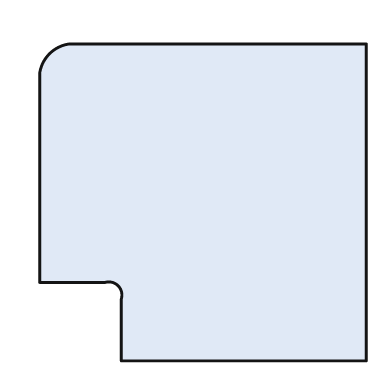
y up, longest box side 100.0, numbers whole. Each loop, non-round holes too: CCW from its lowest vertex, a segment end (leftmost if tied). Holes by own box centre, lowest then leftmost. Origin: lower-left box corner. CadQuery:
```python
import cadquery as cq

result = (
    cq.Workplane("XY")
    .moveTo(25.0, 0.0)
    .lineTo(100.0, 0.0)
    .lineTo(100.0, 97.0)
    .lineTo(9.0, 97.0)
    .threePointArc((3.0, 94.0), (0.0, 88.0))
    .lineTo(0.0, 24.0)
    .lineTo(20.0, 24.0)
    .threePointArc((24.0, 23.0), (25.0, 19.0))
    .close()
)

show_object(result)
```